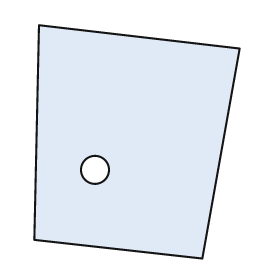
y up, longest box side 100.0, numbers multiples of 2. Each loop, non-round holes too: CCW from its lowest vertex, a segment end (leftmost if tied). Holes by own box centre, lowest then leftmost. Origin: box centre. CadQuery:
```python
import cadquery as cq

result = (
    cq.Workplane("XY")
    .moveTo(28.0, -50.0)
    .lineTo(44.0, 40.0)
    .lineTo(-42.0, 50.0)
    .lineTo(-44.0, -42.0)
    .close()
    .moveTo(-18.0, -12.0)
    .circle(6.0)
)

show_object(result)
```